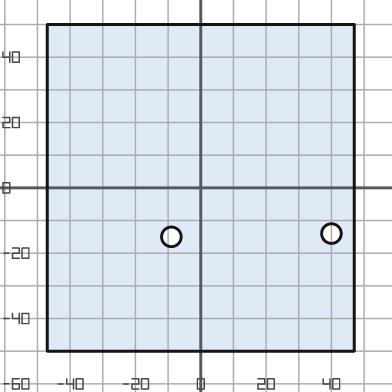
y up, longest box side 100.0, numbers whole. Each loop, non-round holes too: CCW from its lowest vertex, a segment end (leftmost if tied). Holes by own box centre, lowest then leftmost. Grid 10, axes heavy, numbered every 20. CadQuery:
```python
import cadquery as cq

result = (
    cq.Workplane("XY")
    .moveTo(-47.0, -50.0)
    .lineTo(47.0, -50.0)
    .lineTo(47.0, 50.0)
    .lineTo(-47.0, 50.0)
    .close()
    .moveTo(-9.0, -15.0)
    .circle(3.0)
    .moveTo(40.0, -14.0)
    .circle(3.0)
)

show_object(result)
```